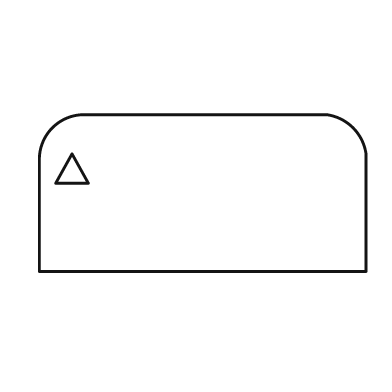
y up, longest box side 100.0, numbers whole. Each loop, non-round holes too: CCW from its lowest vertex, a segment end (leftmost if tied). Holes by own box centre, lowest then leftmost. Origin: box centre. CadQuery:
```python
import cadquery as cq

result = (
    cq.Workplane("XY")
    .moveTo(-50.0, -24.0)
    .lineTo(50.0, -24.0)
    .lineTo(50.0, 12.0)
    .threePointArc((46.0, 20.0), (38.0, 24.0))
    .lineTo(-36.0, 24.0)
    .threePointArc((-46.0, 20.0), (-50.0, 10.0))
    .close()
    .moveTo(-45.0, 3.0)
    .lineTo(-35.0, 3.0)
    .lineTo(-40.0, 12.0)
    .close()
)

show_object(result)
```